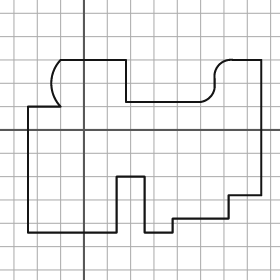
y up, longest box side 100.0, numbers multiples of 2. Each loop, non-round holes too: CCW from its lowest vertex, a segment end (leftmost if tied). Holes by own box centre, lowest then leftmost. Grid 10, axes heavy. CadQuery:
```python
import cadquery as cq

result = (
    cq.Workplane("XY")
    .moveTo(-24.0, -44.0)
    .lineTo(14.0, -44.0)
    .lineTo(14.0, -20.0)
    .lineTo(26.0, -20.0)
    .lineTo(26.0, -44.0)
    .lineTo(38.0, -44.0)
    .lineTo(38.0, -38.0)
    .lineTo(62.0, -38.0)
    .lineTo(62.0, -28.0)
    .lineTo(76.0, -28.0)
    .lineTo(76.0, 30.0)
    .lineTo(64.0, 30.0)
    .threePointArc((58.0, 28.0), (56.0, 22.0))
    .lineTo(56.0, 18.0)
    .threePointArc((54.0, 14.0), (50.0, 12.0))
    .lineTo(18.0, 12.0)
    .lineTo(18.0, 30.0)
    .lineTo(-10.0, 30.0)
    .threePointArc((-14.0, 20.0), (-10.0, 10.0))
    .lineTo(-24.0, 10.0)
    .close()
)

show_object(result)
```